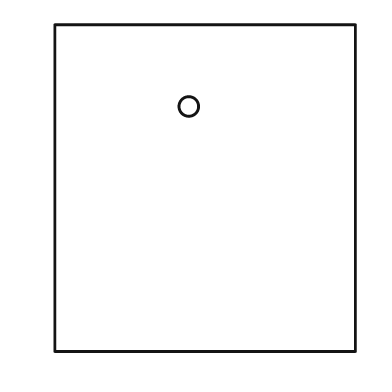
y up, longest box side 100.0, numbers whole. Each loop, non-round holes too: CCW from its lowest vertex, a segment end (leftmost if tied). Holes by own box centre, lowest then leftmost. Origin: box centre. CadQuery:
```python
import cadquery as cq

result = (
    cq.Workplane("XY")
    .moveTo(-46.0, -50.0)
    .lineTo(46.0, -50.0)
    .lineTo(46.0, 50.0)
    .lineTo(-46.0, 50.0)
    .close()
    .moveTo(-5.0, 25.0)
    .circle(3.0)
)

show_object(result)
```